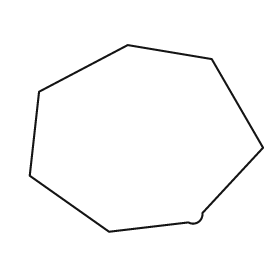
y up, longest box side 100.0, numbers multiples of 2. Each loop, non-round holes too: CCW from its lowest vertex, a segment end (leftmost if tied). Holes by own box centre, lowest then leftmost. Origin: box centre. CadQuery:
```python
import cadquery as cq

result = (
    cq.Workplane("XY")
    .moveTo(-16.0, -40.0)
    .lineTo(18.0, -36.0)
    .threePointArc((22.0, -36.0), (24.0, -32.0))
    .lineTo(50.0, -4.0)
    .lineTo(28.0, 34.0)
    .lineTo(-8.0, 40.0)
    .lineTo(-46.0, 20.0)
    .lineTo(-50.0, -16.0)
    .close()
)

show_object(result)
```